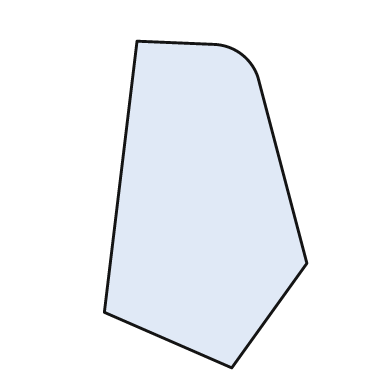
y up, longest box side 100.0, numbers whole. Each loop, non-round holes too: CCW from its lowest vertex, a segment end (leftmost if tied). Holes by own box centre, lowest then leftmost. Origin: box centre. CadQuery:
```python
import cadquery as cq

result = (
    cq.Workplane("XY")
    .moveTo(8.0, -50.0)
    .lineTo(31.0, -18.0)
    .lineTo(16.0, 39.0)
    .threePointArc((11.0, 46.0), (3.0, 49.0))
    .lineTo(-21.0, 50.0)
    .lineTo(-31.0, -33.0)
    .close()
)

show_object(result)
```